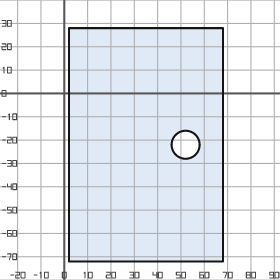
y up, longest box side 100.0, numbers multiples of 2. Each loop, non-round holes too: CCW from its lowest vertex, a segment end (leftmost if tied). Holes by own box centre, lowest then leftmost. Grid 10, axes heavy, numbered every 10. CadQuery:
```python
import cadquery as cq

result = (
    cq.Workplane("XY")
    .moveTo(2.0, -72.0)
    .lineTo(68.0, -72.0)
    .lineTo(68.0, 28.0)
    .lineTo(2.0, 28.0)
    .close()
    .moveTo(52.0, -22.0)
    .circle(6.0)
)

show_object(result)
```